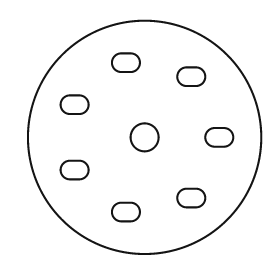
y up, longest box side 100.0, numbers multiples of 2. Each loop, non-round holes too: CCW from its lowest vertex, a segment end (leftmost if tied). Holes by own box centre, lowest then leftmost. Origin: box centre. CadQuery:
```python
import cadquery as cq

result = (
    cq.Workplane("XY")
    .moveTo(0.0, 0.0)
    .circle(50.0)
    .moveTo(-10.0, -36.0)
    .lineTo(-6.0, -36.0)
    .threePointArc((-2.0, -32.0), (-6.0, -28.0))
    .lineTo(-10.0, -28.0)
    .threePointArc((-14.0, -32.0), (-10.0, -36.0))
    .close()
    .moveTo(18.0, -30.0)
    .lineTo(22.0, -30.0)
    .threePointArc((26.0, -26.0), (22.0, -22.0))
    .lineTo(18.0, -22.0)
    .threePointArc((14.0, -26.0), (18.0, -30.0))
    .close()
    .moveTo(-32.0, -18.0)
    .lineTo(-28.0, -18.0)
    .threePointArc((-24.0, -14.0), (-28.0, -10.0))
    .lineTo(-32.0, -10.0)
    .threePointArc((-36.0, -14.0), (-32.0, -18.0))
    .close()
    .moveTo(0.0, 0.0)
    .circle(6.0)
    .moveTo(30.0, -4.0)
    .lineTo(34.0, -4.0)
    .threePointArc((38.0, 0.0), (34.0, 4.0))
    .lineTo(30.0, 4.0)
    .threePointArc((26.0, 0.0), (30.0, -4.0))
    .close()
    .moveTo(-32.0, 10.0)
    .lineTo(-28.0, 10.0)
    .threePointArc((-24.0, 14.0), (-28.0, 18.0))
    .lineTo(-32.0, 18.0)
    .threePointArc((-36.0, 14.0), (-32.0, 10.0))
    .close()
    .moveTo(18.0, 22.0)
    .lineTo(22.0, 22.0)
    .threePointArc((26.0, 26.0), (22.0, 30.0))
    .lineTo(18.0, 30.0)
    .threePointArc((14.0, 26.0), (18.0, 22.0))
    .close()
    .moveTo(-10.0, 28.0)
    .lineTo(-6.0, 28.0)
    .threePointArc((-2.0, 32.0), (-6.0, 36.0))
    .lineTo(-10.0, 36.0)
    .threePointArc((-14.0, 32.0), (-10.0, 28.0))
    .close()
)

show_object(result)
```